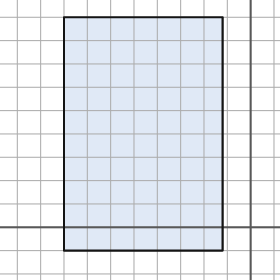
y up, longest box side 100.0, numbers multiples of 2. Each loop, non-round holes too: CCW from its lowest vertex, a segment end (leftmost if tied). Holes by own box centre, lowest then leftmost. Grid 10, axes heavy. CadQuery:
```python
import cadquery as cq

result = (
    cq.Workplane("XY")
    .moveTo(-80.0, -10.0)
    .lineTo(-12.0, -10.0)
    .lineTo(-12.0, 90.0)
    .lineTo(-80.0, 90.0)
    .close()
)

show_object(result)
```